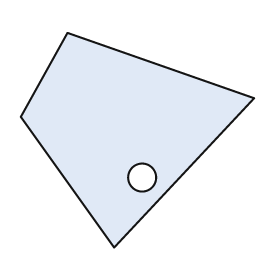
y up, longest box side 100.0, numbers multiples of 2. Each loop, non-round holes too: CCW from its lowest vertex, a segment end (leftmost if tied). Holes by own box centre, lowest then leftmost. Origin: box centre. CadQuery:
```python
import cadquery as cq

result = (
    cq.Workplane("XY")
    .moveTo(-10.0, -46.0)
    .lineTo(50.0, 18.0)
    .lineTo(-30.0, 46.0)
    .lineTo(-50.0, 10.0)
    .close()
    .moveTo(2.0, -16.0)
    .circle(6.0)
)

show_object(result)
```